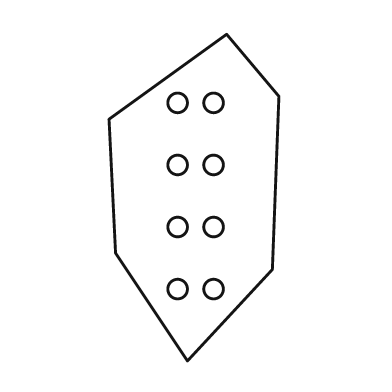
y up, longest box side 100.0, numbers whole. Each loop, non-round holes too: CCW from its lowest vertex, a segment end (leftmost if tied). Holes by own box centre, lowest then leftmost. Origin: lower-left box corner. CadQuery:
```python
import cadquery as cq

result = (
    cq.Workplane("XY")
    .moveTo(24.0, 0.0)
    .lineTo(50.0, 28.0)
    .lineTo(52.0, 81.0)
    .lineTo(36.0, 100.0)
    .lineTo(0.0, 74.0)
    .lineTo(2.0, 33.0)
    .close()
    .moveTo(21.0, 22.0)
    .circle(3.0)
    .moveTo(32.0, 22.0)
    .circle(3.0)
    .moveTo(21.0, 41.0)
    .circle(3.0)
    .moveTo(32.0, 41.0)
    .circle(3.0)
    .moveTo(21.0, 60.0)
    .circle(3.0)
    .moveTo(32.0, 60.0)
    .circle(3.0)
    .moveTo(21.0, 79.0)
    .circle(3.0)
    .moveTo(32.0, 79.0)
    .circle(3.0)
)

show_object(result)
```